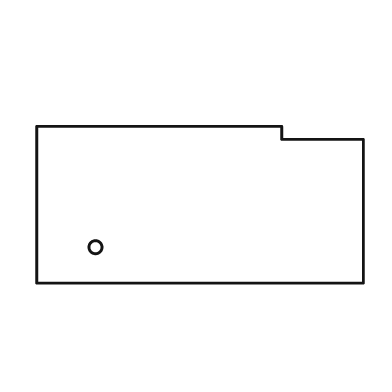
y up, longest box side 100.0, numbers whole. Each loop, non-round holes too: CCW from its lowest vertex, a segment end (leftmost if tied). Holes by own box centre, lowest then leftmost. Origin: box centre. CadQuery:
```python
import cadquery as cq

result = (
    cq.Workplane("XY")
    .moveTo(-50.0, -24.0)
    .lineTo(50.0, -24.0)
    .lineTo(50.0, 20.0)
    .lineTo(25.0, 20.0)
    .lineTo(25.0, 24.0)
    .lineTo(-50.0, 24.0)
    .close()
    .moveTo(-32.0, -13.0)
    .circle(2.0)
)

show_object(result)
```